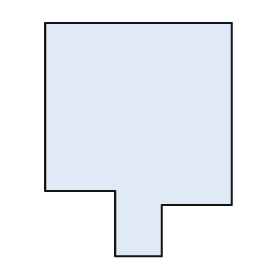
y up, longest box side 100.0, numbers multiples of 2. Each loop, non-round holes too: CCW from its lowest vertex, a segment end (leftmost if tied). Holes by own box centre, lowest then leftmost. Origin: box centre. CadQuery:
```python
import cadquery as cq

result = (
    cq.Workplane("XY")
    .moveTo(-10.0, -50.0)
    .lineTo(10.0, -50.0)
    .lineTo(10.0, -28.0)
    .lineTo(40.0, -28.0)
    .lineTo(40.0, 50.0)
    .lineTo(-40.0, 50.0)
    .lineTo(-40.0, -22.0)
    .lineTo(-10.0, -22.0)
    .close()
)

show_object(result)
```